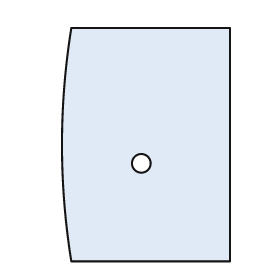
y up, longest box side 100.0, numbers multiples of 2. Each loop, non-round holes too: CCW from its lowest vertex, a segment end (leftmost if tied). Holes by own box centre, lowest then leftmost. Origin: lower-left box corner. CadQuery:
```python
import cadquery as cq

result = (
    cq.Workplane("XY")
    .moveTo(4.0, 0.0)
    .lineTo(72.0, 0.0)
    .lineTo(72.0, 100.0)
    .lineTo(4.0, 100.0)
    .threePointArc((0.0, 50.0), (4.0, 0.0))
    .close()
    .moveTo(34.0, 42.0)
    .circle(4.0)
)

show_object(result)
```